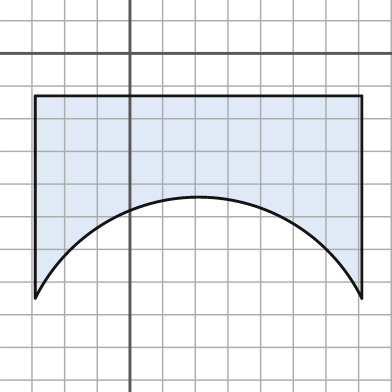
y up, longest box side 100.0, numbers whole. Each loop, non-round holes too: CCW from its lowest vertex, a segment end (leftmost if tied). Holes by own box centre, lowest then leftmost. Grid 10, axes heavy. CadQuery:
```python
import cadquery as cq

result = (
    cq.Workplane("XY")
    .moveTo(-29.0, -75.0)
    .threePointArc((21.0, -44.0), (71.0, -75.0))
    .lineTo(71.0, -13.0)
    .lineTo(-29.0, -13.0)
    .close()
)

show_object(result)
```